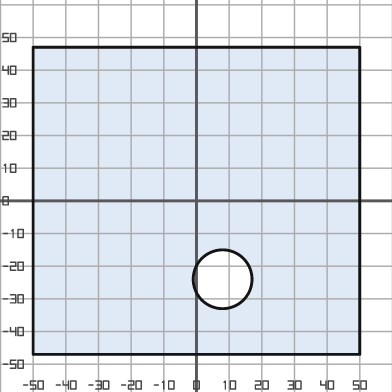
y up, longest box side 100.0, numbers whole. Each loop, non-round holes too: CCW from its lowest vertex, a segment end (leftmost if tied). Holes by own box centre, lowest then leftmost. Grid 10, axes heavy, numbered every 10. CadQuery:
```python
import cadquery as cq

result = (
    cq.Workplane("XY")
    .moveTo(-50.0, -47.0)
    .lineTo(50.0, -47.0)
    .lineTo(50.0, 47.0)
    .lineTo(-50.0, 47.0)
    .close()
    .moveTo(8.0, -24.0)
    .circle(9.0)
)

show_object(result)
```